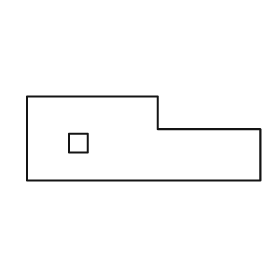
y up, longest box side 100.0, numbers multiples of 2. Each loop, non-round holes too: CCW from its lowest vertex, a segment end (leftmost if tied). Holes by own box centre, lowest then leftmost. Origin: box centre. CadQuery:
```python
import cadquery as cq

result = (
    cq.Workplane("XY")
    .moveTo(-50.0, -18.0)
    .lineTo(50.0, -18.0)
    .lineTo(50.0, 4.0)
    .lineTo(6.0, 4.0)
    .lineTo(6.0, 18.0)
    .lineTo(-50.0, 18.0)
    .close()
    .moveTo(-32.0, -6.0)
    .lineTo(-24.0, -6.0)
    .lineTo(-24.0, 2.0)
    .lineTo(-32.0, 2.0)
    .close()
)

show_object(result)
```